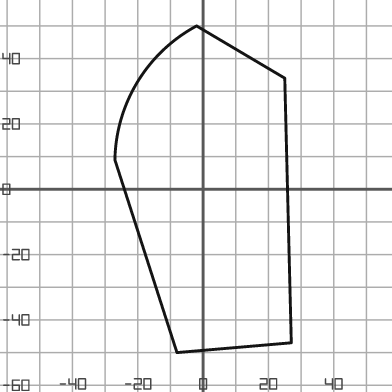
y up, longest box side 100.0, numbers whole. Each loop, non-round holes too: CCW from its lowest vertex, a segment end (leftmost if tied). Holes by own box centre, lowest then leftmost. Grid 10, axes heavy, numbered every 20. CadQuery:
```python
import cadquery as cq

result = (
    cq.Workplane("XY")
    .moveTo(-8.0, -50.0)
    .lineTo(27.0, -47.0)
    .lineTo(25.0, 34.0)
    .lineTo(-2.0, 50.0)
    .threePointArc((-20.0, 33.0), (-27.0, 9.0))
    .close()
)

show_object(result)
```